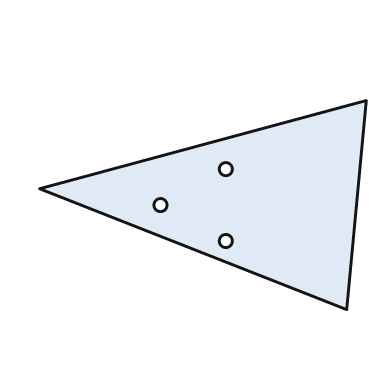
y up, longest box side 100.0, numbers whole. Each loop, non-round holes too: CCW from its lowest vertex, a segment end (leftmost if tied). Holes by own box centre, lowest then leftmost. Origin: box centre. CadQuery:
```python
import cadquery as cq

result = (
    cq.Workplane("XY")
    .moveTo(44.0, -32.0)
    .lineTo(50.0, 32.0)
    .lineTo(-50.0, 5.0)
    .close()
    .moveTo(7.0, -11.0)
    .circle(2.0)
    .moveTo(-13.0, 0.0)
    .circle(2.0)
    .moveTo(7.0, 11.0)
    .circle(2.0)
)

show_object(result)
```